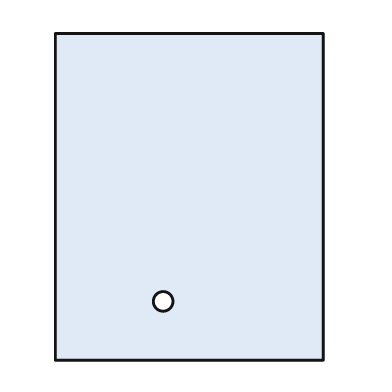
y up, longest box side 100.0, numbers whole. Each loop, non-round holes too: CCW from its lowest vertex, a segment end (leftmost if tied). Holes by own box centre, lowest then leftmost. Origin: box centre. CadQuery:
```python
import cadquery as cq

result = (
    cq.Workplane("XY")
    .moveTo(-41.0, -50.0)
    .lineTo(41.0, -50.0)
    .lineTo(41.0, 50.0)
    .lineTo(-41.0, 50.0)
    .close()
    .moveTo(-8.0, -32.0)
    .circle(3.0)
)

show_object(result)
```